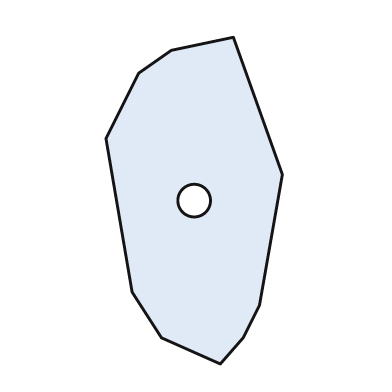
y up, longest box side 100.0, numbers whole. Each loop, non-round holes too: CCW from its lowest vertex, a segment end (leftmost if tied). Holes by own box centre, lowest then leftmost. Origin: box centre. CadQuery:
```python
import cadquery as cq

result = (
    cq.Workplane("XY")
    .moveTo(8.0, -50.0)
    .lineTo(15.0, -42.0)
    .lineTo(20.0, -32.0)
    .lineTo(27.0, 8.0)
    .lineTo(12.0, 50.0)
    .lineTo(-7.0, 46.0)
    .lineTo(-17.0, 39.0)
    .lineTo(-27.0, 19.0)
    .lineTo(-19.0, -28.0)
    .lineTo(-10.0, -42.0)
    .close()
    .moveTo(0.0, 0.0)
    .circle(5.0)
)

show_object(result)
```